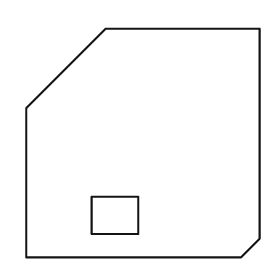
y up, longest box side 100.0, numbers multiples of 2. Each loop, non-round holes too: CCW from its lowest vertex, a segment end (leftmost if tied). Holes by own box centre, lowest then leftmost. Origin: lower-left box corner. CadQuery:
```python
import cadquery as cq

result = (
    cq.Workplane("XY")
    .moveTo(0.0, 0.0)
    .lineTo(92.0, 0.0)
    .lineTo(100.0, 8.0)
    .lineTo(100.0, 98.0)
    .lineTo(34.0, 98.0)
    .lineTo(0.0, 64.0)
    .close()
    .moveTo(28.0, 10.0)
    .lineTo(48.0, 10.0)
    .lineTo(48.0, 26.0)
    .lineTo(28.0, 26.0)
    .close()
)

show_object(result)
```